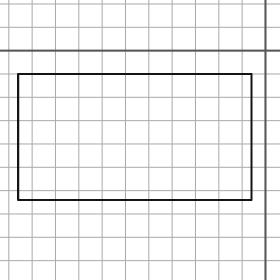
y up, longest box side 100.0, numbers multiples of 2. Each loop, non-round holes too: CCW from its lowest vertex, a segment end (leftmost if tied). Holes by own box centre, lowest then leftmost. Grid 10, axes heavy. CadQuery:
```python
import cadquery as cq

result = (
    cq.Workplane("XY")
    .moveTo(-106.0, -64.0)
    .lineTo(-6.0, -64.0)
    .lineTo(-6.0, -10.0)
    .lineTo(-106.0, -10.0)
    .close()
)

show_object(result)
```